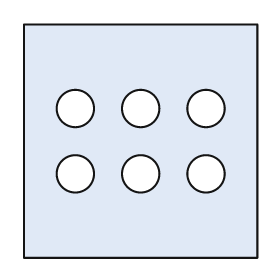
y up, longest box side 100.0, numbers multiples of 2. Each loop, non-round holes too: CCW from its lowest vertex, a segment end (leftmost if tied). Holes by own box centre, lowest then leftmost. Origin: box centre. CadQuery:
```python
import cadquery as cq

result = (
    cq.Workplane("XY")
    .moveTo(-50.0, -50.0)
    .lineTo(50.0, -50.0)
    .lineTo(50.0, 50.0)
    .lineTo(-50.0, 50.0)
    .close()
    .moveTo(-28.0, -14.0)
    .circle(8.0)
    .moveTo(0.0, -14.0)
    .circle(8.0)
    .moveTo(28.0, -14.0)
    .circle(8.0)
    .moveTo(-28.0, 14.0)
    .circle(8.0)
    .moveTo(0.0, 14.0)
    .circle(8.0)
    .moveTo(28.0, 14.0)
    .circle(8.0)
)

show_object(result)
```